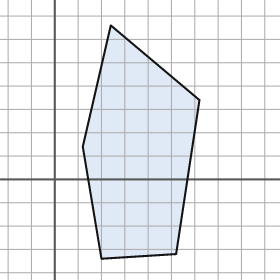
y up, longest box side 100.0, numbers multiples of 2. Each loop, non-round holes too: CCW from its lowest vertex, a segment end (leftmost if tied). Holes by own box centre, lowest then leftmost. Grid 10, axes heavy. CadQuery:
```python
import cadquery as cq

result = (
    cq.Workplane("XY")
    .moveTo(20.0, -34.0)
    .lineTo(52.0, -32.0)
    .lineTo(62.0, 34.0)
    .lineTo(24.0, 66.0)
    .lineTo(12.0, 14.0)
    .close()
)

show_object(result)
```